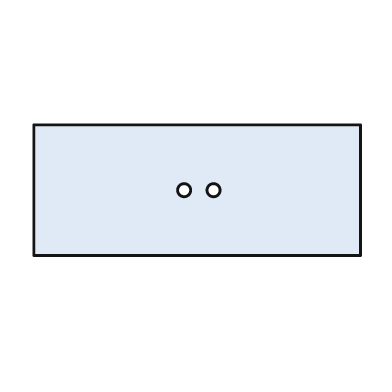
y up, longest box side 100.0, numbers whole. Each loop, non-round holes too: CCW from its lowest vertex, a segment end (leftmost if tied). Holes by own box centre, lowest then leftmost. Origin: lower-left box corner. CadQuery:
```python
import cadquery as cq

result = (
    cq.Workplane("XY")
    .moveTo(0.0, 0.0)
    .lineTo(100.0, 0.0)
    .lineTo(100.0, 40.0)
    .lineTo(0.0, 40.0)
    .close()
    .moveTo(46.0, 20.0)
    .circle(2.0)
    .moveTo(55.0, 20.0)
    .circle(2.0)
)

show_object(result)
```